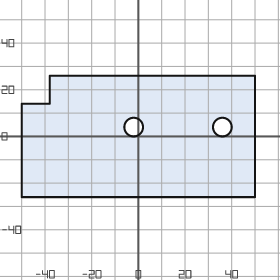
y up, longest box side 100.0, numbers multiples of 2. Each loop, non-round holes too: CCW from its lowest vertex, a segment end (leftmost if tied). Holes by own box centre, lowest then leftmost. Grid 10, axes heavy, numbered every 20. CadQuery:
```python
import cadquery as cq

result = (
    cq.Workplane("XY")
    .moveTo(-50.0, -26.0)
    .lineTo(50.0, -26.0)
    .lineTo(50.0, 26.0)
    .lineTo(-38.0, 26.0)
    .lineTo(-38.0, 14.0)
    .lineTo(-50.0, 14.0)
    .close()
    .moveTo(-2.0, 4.0)
    .circle(4.0)
    .moveTo(36.0, 4.0)
    .circle(4.0)
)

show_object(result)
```